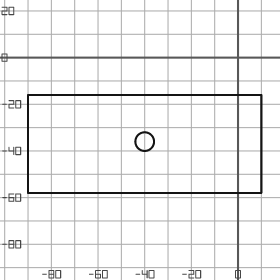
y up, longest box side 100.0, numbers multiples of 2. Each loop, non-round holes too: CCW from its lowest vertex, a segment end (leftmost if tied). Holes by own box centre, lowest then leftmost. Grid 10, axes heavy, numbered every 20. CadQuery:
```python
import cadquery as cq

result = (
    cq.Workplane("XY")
    .moveTo(-90.0, -58.0)
    .lineTo(10.0, -58.0)
    .lineTo(10.0, -16.0)
    .lineTo(-90.0, -16.0)
    .close()
    .moveTo(-40.0, -36.0)
    .circle(4.0)
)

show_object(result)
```